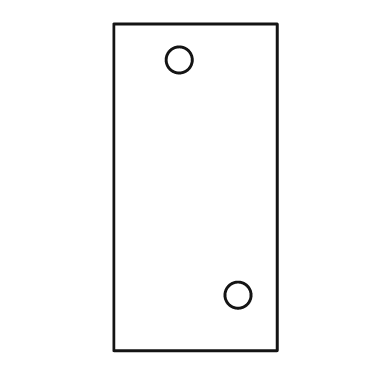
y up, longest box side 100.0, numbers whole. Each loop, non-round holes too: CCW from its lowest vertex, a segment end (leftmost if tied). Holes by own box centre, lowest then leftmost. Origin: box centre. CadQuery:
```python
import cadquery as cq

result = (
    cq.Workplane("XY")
    .moveTo(-25.0, -50.0)
    .lineTo(25.0, -50.0)
    .lineTo(25.0, 50.0)
    .lineTo(-25.0, 50.0)
    .close()
    .moveTo(13.0, -33.0)
    .circle(4.0)
    .moveTo(-5.0, 39.0)
    .circle(4.0)
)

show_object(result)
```